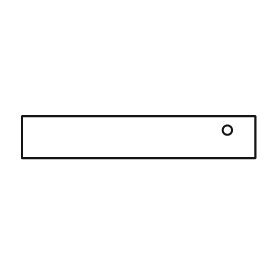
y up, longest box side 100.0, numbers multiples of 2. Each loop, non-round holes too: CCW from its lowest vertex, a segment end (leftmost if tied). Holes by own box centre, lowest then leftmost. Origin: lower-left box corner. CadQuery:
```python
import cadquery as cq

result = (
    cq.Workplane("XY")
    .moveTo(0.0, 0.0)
    .lineTo(100.0, 0.0)
    .lineTo(100.0, 18.0)
    .lineTo(0.0, 18.0)
    .close()
    .moveTo(88.0, 12.0)
    .circle(2.0)
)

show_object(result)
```